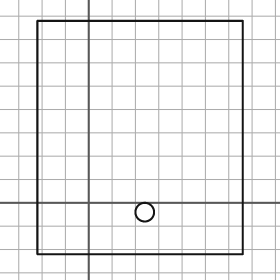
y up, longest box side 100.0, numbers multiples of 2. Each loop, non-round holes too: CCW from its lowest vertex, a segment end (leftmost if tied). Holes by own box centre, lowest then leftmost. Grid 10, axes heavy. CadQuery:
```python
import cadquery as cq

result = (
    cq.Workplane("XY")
    .moveTo(-22.0, -22.0)
    .lineTo(66.0, -22.0)
    .lineTo(66.0, 78.0)
    .lineTo(-22.0, 78.0)
    .close()
    .moveTo(24.0, -4.0)
    .circle(4.0)
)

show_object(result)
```